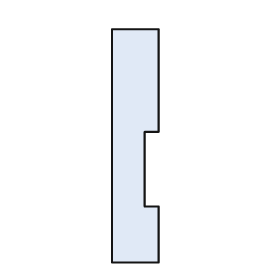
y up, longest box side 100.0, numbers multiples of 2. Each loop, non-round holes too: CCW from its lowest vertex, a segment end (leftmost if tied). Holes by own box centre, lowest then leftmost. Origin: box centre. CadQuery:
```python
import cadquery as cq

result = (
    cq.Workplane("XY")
    .moveTo(-10.0, -50.0)
    .lineTo(10.0, -50.0)
    .lineTo(10.0, -26.0)
    .lineTo(4.0, -26.0)
    .lineTo(4.0, 6.0)
    .lineTo(10.0, 6.0)
    .lineTo(10.0, 50.0)
    .lineTo(-10.0, 50.0)
    .close()
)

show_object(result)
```